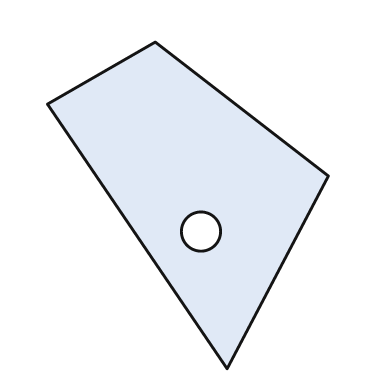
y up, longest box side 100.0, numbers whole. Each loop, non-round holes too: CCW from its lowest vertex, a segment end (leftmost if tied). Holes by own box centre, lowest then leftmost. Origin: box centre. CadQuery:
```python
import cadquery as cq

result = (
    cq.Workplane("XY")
    .moveTo(12.0, -50.0)
    .lineTo(43.0, 9.0)
    .lineTo(-10.0, 50.0)
    .lineTo(-43.0, 31.0)
    .close()
    .moveTo(4.0, -8.0)
    .circle(6.0)
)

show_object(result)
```